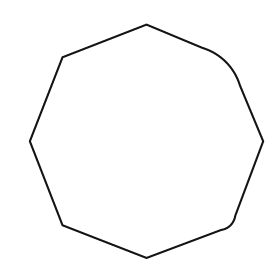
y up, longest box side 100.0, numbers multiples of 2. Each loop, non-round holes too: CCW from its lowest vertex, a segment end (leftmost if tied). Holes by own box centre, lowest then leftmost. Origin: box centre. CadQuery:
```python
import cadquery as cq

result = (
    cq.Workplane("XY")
    .moveTo(0.0, -50.0)
    .lineTo(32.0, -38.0)
    .threePointArc((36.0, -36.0), (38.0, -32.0))
    .lineTo(50.0, 0.0)
    .lineTo(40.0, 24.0)
    .threePointArc((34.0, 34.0), (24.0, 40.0))
    .lineTo(0.0, 50.0)
    .lineTo(-36.0, 36.0)
    .lineTo(-50.0, 0.0)
    .lineTo(-36.0, -36.0)
    .close()
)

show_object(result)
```